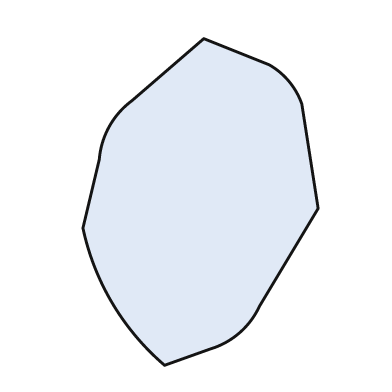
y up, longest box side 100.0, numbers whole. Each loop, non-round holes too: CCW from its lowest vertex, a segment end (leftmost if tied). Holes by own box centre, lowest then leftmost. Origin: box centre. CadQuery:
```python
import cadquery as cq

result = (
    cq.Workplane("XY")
    .moveTo(-11.0, -50.0)
    .lineTo(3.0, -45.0)
    .threePointArc((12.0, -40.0), (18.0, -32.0))
    .lineTo(36.0, -2.0)
    .lineTo(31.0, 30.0)
    .threePointArc((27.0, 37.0), (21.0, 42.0))
    .lineTo(1.0, 50.0)
    .lineTo(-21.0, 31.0)
    .threePointArc((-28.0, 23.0), (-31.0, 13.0))
    .lineTo(-36.0, -8.0)
    .threePointArc((-27.0, -31.0), (-11.0, -50.0))
    .close()
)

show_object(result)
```